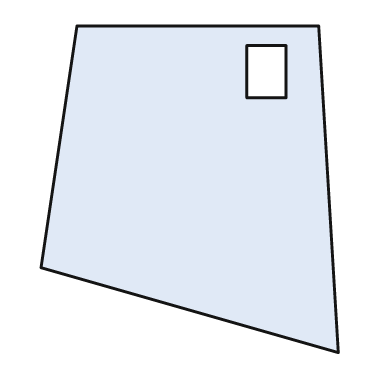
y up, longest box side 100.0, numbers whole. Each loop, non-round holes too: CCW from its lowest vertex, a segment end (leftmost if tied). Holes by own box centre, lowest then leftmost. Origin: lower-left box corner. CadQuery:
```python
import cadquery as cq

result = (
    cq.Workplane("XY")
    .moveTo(91.0, 0.0)
    .lineTo(85.0, 100.0)
    .lineTo(11.0, 100.0)
    .lineTo(0.0, 26.0)
    .close()
    .moveTo(63.0, 78.0)
    .lineTo(75.0, 78.0)
    .lineTo(75.0, 94.0)
    .lineTo(63.0, 94.0)
    .close()
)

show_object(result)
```